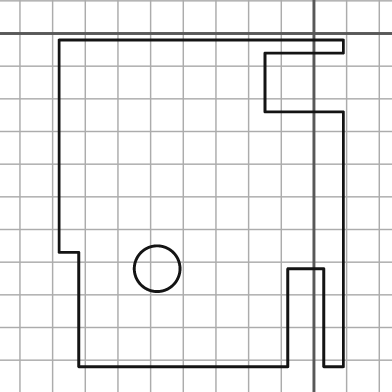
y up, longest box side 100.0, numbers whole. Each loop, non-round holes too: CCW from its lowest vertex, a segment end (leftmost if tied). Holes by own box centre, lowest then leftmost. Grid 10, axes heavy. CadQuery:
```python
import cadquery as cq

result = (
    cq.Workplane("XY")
    .moveTo(-72.0, -102.0)
    .lineTo(-8.0, -102.0)
    .lineTo(-8.0, -72.0)
    .lineTo(3.0, -72.0)
    .lineTo(3.0, -102.0)
    .lineTo(9.0, -102.0)
    .lineTo(9.0, -24.0)
    .lineTo(-15.0, -24.0)
    .lineTo(-15.0, -6.0)
    .lineTo(9.0, -6.0)
    .lineTo(9.0, -2.0)
    .lineTo(-78.0, -2.0)
    .lineTo(-78.0, -67.0)
    .lineTo(-72.0, -67.0)
    .close()
    .moveTo(-48.0, -72.0)
    .circle(7.0)
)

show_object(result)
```